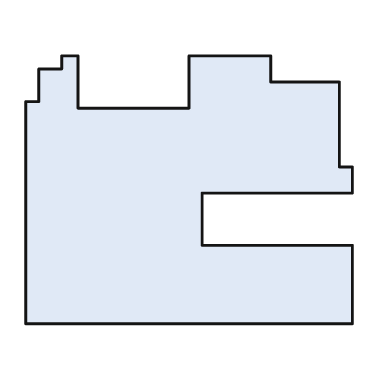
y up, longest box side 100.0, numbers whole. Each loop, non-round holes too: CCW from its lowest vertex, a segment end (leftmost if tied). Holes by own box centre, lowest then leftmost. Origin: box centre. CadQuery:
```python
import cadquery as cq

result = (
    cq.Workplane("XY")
    .moveTo(-50.0, -41.0)
    .lineTo(50.0, -41.0)
    .lineTo(50.0, -17.0)
    .lineTo(4.0, -17.0)
    .lineTo(4.0, -1.0)
    .lineTo(50.0, -1.0)
    .lineTo(50.0, 7.0)
    .lineTo(46.0, 7.0)
    .lineTo(46.0, 33.0)
    .lineTo(25.0, 33.0)
    .lineTo(25.0, 41.0)
    .lineTo(0.0, 41.0)
    .lineTo(0.0, 25.0)
    .lineTo(-34.0, 25.0)
    .lineTo(-34.0, 41.0)
    .lineTo(-39.0, 41.0)
    .lineTo(-39.0, 37.0)
    .lineTo(-46.0, 37.0)
    .lineTo(-46.0, 27.0)
    .lineTo(-50.0, 27.0)
    .close()
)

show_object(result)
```